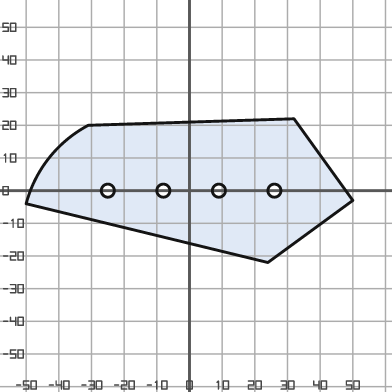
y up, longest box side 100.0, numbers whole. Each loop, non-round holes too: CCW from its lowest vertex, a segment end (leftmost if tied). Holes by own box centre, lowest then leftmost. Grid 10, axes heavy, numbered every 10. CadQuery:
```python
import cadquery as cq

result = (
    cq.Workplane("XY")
    .moveTo(24.0, -22.0)
    .lineTo(50.0, -3.0)
    .lineTo(32.0, 22.0)
    .lineTo(-31.0, 20.0)
    .threePointArc((-43.0, 10.0), (-50.0, -4.0))
    .close()
    .moveTo(-25.0, 0.0)
    .circle(2.0)
    .moveTo(-8.0, 0.0)
    .circle(2.0)
    .moveTo(9.0, 0.0)
    .circle(2.0)
    .moveTo(26.0, 0.0)
    .circle(2.0)
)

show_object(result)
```